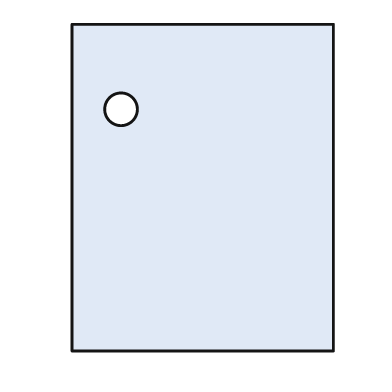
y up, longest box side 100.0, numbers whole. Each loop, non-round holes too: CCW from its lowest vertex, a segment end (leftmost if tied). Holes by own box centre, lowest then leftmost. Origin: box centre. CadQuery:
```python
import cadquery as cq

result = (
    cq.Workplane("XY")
    .moveTo(-40.0, -50.0)
    .lineTo(40.0, -50.0)
    .lineTo(40.0, 50.0)
    .lineTo(-40.0, 50.0)
    .close()
    .moveTo(-25.0, 24.0)
    .circle(5.0)
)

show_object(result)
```